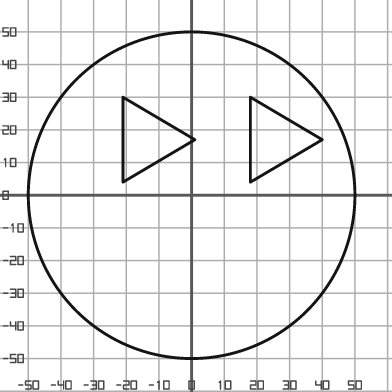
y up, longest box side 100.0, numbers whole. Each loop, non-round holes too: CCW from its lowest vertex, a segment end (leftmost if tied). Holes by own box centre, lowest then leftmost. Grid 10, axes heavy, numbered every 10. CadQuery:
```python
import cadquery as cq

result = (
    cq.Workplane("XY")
    .moveTo(0.0, 0.0)
    .circle(50.0)
    .moveTo(-21.0, 4.0)
    .lineTo(1.0, 17.0)
    .lineTo(-21.0, 30.0)
    .close()
    .moveTo(18.0, 4.0)
    .lineTo(40.0, 17.0)
    .lineTo(18.0, 30.0)
    .close()
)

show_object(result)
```